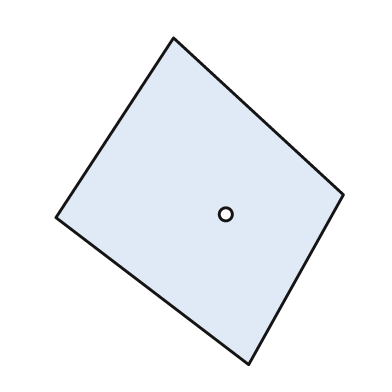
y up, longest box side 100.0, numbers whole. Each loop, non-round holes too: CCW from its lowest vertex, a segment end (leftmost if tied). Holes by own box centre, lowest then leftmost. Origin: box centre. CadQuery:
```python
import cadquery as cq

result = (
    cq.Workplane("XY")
    .moveTo(15.0, -50.0)
    .lineTo(44.0, 2.0)
    .lineTo(-8.0, 50.0)
    .lineTo(-44.0, -5.0)
    .close()
    .moveTo(8.0, -4.0)
    .circle(2.0)
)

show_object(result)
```